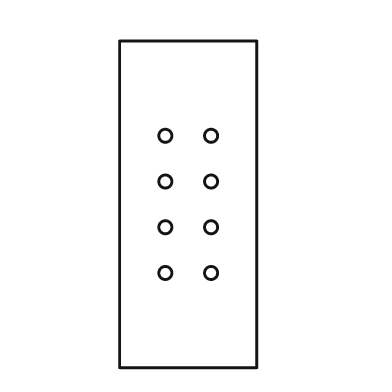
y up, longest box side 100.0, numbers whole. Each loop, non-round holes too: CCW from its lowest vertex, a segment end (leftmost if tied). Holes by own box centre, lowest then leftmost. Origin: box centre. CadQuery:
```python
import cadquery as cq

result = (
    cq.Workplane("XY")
    .moveTo(-21.0, -50.0)
    .lineTo(21.0, -50.0)
    .lineTo(21.0, 50.0)
    .lineTo(-21.0, 50.0)
    .close()
    .moveTo(-7.0, -21.0)
    .circle(2.0)
    .moveTo(7.0, -21.0)
    .circle(2.0)
    .moveTo(-7.0, -7.0)
    .circle(2.0)
    .moveTo(7.0, -7.0)
    .circle(2.0)
    .moveTo(-7.0, 7.0)
    .circle(2.0)
    .moveTo(7.0, 7.0)
    .circle(2.0)
    .moveTo(-7.0, 21.0)
    .circle(2.0)
    .moveTo(7.0, 21.0)
    .circle(2.0)
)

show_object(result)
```